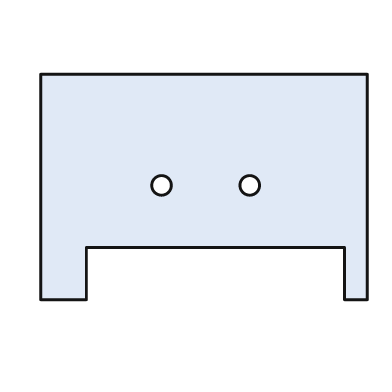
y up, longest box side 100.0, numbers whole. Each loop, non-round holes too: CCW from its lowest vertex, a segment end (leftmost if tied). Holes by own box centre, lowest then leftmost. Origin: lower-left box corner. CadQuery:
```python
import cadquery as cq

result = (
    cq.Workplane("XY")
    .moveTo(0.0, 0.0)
    .lineTo(14.0, 0.0)
    .lineTo(14.0, 16.0)
    .lineTo(93.0, 16.0)
    .lineTo(93.0, 0.0)
    .lineTo(100.0, 0.0)
    .lineTo(100.0, 69.0)
    .lineTo(0.0, 69.0)
    .close()
    .moveTo(37.0, 35.0)
    .circle(3.0)
    .moveTo(64.0, 35.0)
    .circle(3.0)
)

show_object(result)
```